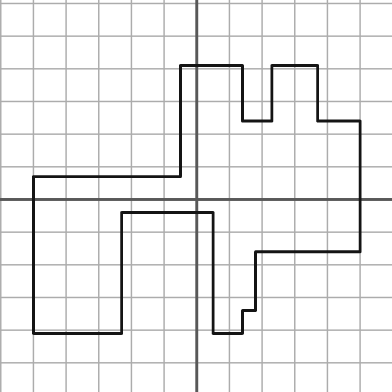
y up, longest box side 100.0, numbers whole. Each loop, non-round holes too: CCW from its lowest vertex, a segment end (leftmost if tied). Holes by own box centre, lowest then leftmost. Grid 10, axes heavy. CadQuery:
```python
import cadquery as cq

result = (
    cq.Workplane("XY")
    .moveTo(-50.0, -41.0)
    .lineTo(-23.0, -41.0)
    .lineTo(-23.0, -4.0)
    .lineTo(5.0, -4.0)
    .lineTo(5.0, -41.0)
    .lineTo(14.0, -41.0)
    .lineTo(14.0, -34.0)
    .lineTo(18.0, -34.0)
    .lineTo(18.0, -16.0)
    .lineTo(50.0, -16.0)
    .lineTo(50.0, 24.0)
    .lineTo(37.0, 24.0)
    .lineTo(37.0, 41.0)
    .lineTo(23.0, 41.0)
    .lineTo(23.0, 24.0)
    .lineTo(14.0, 24.0)
    .lineTo(14.0, 41.0)
    .lineTo(-5.0, 41.0)
    .lineTo(-5.0, 7.0)
    .lineTo(-50.0, 7.0)
    .close()
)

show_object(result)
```